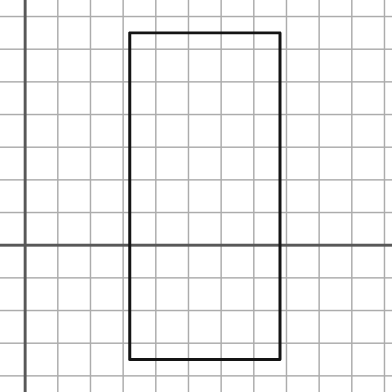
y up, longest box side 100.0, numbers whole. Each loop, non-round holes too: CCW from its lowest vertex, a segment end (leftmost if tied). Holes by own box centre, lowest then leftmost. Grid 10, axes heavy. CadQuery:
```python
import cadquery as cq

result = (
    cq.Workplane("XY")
    .moveTo(32.0, -35.0)
    .lineTo(78.0, -35.0)
    .lineTo(78.0, 65.0)
    .lineTo(32.0, 65.0)
    .close()
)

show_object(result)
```